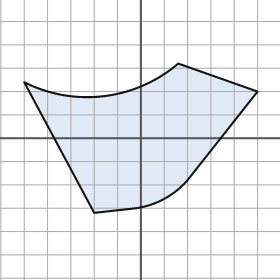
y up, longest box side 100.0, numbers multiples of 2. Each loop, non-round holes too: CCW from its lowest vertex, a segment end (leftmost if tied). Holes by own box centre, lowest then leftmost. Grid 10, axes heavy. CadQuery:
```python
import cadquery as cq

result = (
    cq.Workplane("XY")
    .moveTo(-20.0, -32.0)
    .lineTo(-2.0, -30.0)
    .threePointArc((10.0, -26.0), (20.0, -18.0))
    .lineTo(50.0, 20.0)
    .lineTo(16.0, 32.0)
    .threePointArc((-16.0, 18.0), (-50.0, 24.0))
    .close()
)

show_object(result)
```